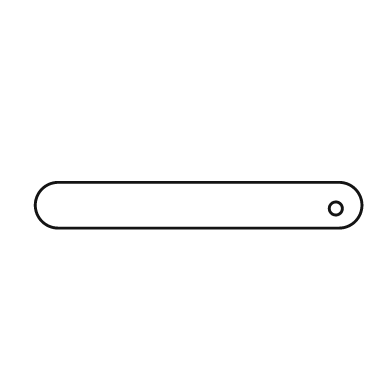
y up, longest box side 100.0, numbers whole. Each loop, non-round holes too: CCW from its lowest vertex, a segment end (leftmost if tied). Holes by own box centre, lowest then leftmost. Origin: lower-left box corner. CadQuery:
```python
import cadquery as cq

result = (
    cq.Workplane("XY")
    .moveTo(7.0, 0.0)
    .lineTo(93.0, 0.0)
    .threePointArc((100.0, 7.0), (93.0, 14.0))
    .lineTo(7.0, 14.0)
    .threePointArc((0.0, 7.0), (7.0, 0.0))
    .close()
    .moveTo(92.0, 6.0)
    .circle(2.0)
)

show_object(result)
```